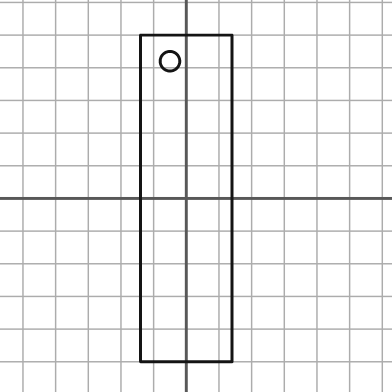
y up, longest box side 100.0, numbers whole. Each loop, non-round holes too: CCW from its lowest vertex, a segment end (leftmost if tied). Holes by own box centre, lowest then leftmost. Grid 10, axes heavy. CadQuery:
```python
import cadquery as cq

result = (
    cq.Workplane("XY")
    .moveTo(-14.0, -50.0)
    .lineTo(14.0, -50.0)
    .lineTo(14.0, 50.0)
    .lineTo(-14.0, 50.0)
    .close()
    .moveTo(-5.0, 42.0)
    .circle(3.0)
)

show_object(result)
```